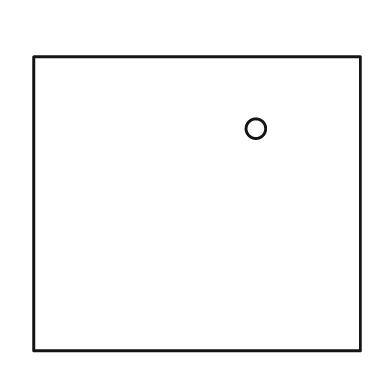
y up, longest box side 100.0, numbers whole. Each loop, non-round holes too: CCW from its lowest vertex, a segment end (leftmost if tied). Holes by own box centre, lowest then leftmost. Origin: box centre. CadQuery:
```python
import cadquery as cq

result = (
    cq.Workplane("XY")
    .moveTo(-50.0, -45.0)
    .lineTo(50.0, -45.0)
    .lineTo(50.0, 45.0)
    .lineTo(-50.0, 45.0)
    .close()
    .moveTo(18.0, 23.0)
    .circle(3.0)
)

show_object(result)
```